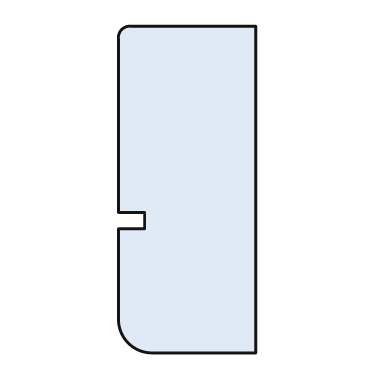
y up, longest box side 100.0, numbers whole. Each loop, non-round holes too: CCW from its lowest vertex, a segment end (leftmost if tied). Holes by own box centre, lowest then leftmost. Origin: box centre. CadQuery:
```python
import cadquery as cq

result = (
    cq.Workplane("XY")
    .moveTo(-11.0, -50.0)
    .lineTo(21.0, -50.0)
    .lineTo(21.0, 50.0)
    .lineTo(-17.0, 50.0)
    .threePointArc((-20.0, 49.0), (-21.0, 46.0))
    .lineTo(-21.0, -7.0)
    .lineTo(-13.0, -7.0)
    .lineTo(-13.0, -12.0)
    .lineTo(-21.0, -12.0)
    .lineTo(-21.0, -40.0)
    .threePointArc((-18.0, -47.0), (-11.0, -50.0))
    .close()
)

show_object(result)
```